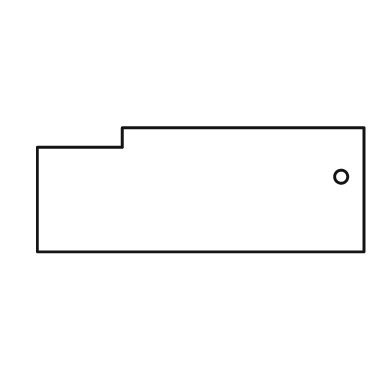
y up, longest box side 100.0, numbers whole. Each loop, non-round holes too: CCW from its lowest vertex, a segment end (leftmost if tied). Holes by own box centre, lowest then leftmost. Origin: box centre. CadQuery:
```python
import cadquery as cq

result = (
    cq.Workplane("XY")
    .moveTo(-50.0, -19.0)
    .lineTo(50.0, -19.0)
    .lineTo(50.0, 19.0)
    .lineTo(-24.0, 19.0)
    .lineTo(-24.0, 13.0)
    .lineTo(-50.0, 13.0)
    .close()
    .moveTo(43.0, 4.0)
    .circle(2.0)
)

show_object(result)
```